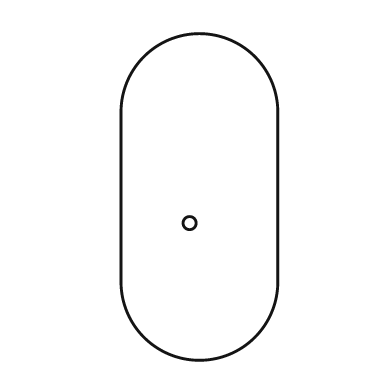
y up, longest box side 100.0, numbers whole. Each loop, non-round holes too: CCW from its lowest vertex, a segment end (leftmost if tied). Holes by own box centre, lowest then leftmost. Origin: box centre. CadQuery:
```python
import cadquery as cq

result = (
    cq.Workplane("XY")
    .moveTo(-24.0, -26.0)
    .threePointArc((0.0, -50.0), (24.0, -26.0))
    .lineTo(24.0, 26.0)
    .threePointArc((0.0, 50.0), (-24.0, 26.0))
    .close()
    .moveTo(-3.0, -8.0)
    .circle(2.0)
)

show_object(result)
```